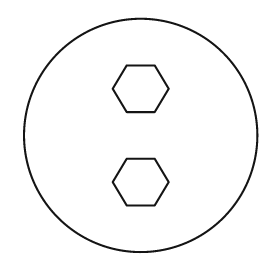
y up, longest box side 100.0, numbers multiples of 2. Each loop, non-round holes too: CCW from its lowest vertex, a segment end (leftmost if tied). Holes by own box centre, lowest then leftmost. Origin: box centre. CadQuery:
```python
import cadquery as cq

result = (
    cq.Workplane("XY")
    .moveTo(0.0, 0.0)
    .circle(50.0)
    .moveTo(-6.0, -30.0)
    .lineTo(6.0, -30.0)
    .lineTo(12.0, -20.0)
    .lineTo(6.0, -10.0)
    .lineTo(-6.0, -10.0)
    .lineTo(-12.0, -20.0)
    .close()
    .moveTo(-6.0, 10.0)
    .lineTo(6.0, 10.0)
    .lineTo(12.0, 20.0)
    .lineTo(6.0, 30.0)
    .lineTo(-6.0, 30.0)
    .lineTo(-12.0, 20.0)
    .close()
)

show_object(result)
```